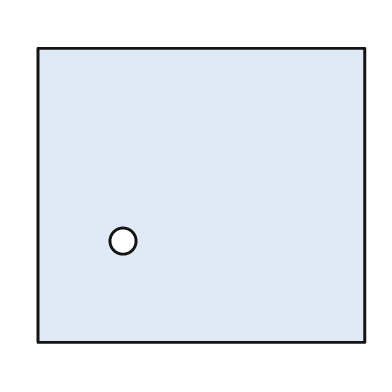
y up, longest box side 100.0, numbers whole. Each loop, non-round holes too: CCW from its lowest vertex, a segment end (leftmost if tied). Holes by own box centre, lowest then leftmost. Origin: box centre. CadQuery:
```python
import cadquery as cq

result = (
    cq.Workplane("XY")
    .moveTo(-50.0, -45.0)
    .lineTo(50.0, -45.0)
    .lineTo(50.0, 45.0)
    .lineTo(-50.0, 45.0)
    .close()
    .moveTo(-24.0, -14.0)
    .circle(4.0)
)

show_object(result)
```